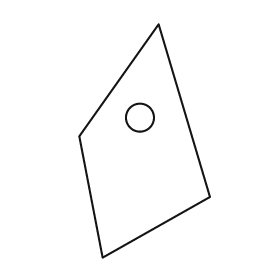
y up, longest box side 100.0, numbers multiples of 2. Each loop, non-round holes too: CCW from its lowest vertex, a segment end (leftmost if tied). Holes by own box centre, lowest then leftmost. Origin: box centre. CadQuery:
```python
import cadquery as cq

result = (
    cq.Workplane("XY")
    .moveTo(-18.0, -50.0)
    .lineTo(28.0, -24.0)
    .lineTo(6.0, 50.0)
    .lineTo(-28.0, 2.0)
    .close()
    .moveTo(-2.0, 10.0)
    .circle(6.0)
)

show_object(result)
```